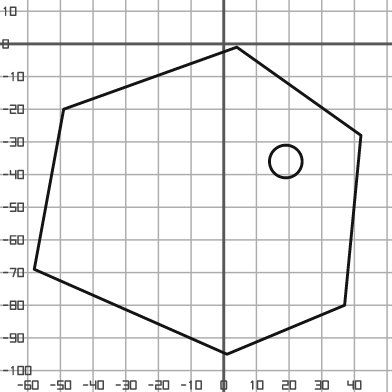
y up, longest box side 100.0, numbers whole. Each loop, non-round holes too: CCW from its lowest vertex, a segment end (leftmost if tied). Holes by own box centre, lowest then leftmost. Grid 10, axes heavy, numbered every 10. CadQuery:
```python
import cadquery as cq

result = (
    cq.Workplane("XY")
    .moveTo(1.0, -95.0)
    .lineTo(37.0, -80.0)
    .lineTo(42.0, -28.0)
    .lineTo(4.0, -1.0)
    .lineTo(-49.0, -20.0)
    .lineTo(-58.0, -69.0)
    .close()
    .moveTo(19.0, -36.0)
    .circle(5.0)
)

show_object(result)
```